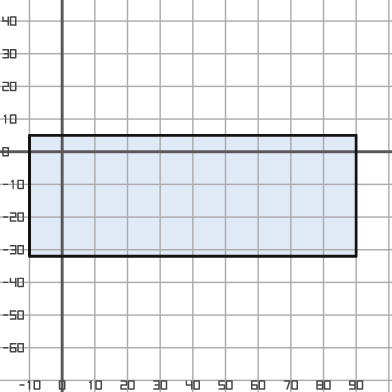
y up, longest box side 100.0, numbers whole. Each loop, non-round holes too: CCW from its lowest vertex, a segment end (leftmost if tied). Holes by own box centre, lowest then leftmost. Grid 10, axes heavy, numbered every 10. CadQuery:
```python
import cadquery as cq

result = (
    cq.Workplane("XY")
    .moveTo(-10.0, -32.0)
    .lineTo(90.0, -32.0)
    .lineTo(90.0, 5.0)
    .lineTo(-10.0, 5.0)
    .close()
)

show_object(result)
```